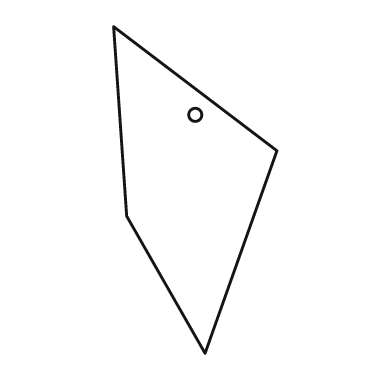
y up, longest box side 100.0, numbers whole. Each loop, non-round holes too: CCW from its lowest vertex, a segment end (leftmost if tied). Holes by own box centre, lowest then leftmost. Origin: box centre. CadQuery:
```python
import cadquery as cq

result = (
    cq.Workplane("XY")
    .moveTo(3.0, -50.0)
    .lineTo(25.0, 12.0)
    .lineTo(-25.0, 50.0)
    .lineTo(-21.0, -8.0)
    .close()
    .moveTo(0.0, 23.0)
    .circle(2.0)
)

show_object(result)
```